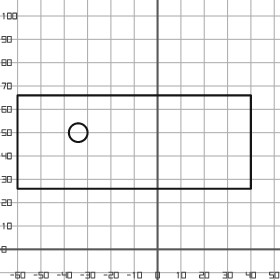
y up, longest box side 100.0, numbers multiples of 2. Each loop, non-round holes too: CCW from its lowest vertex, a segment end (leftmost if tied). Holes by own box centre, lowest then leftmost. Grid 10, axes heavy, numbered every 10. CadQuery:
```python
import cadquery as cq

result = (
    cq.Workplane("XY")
    .moveTo(-60.0, 26.0)
    .lineTo(40.0, 26.0)
    .lineTo(40.0, 66.0)
    .lineTo(-60.0, 66.0)
    .close()
    .moveTo(-34.0, 50.0)
    .circle(4.0)
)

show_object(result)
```